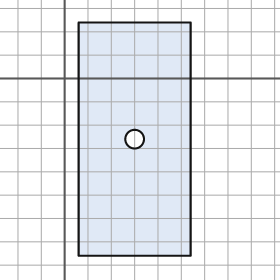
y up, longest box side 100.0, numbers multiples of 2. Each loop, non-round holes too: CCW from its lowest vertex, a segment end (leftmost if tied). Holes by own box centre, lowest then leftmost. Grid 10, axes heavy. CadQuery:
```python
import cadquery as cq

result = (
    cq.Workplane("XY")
    .moveTo(6.0, -76.0)
    .lineTo(54.0, -76.0)
    .lineTo(54.0, 24.0)
    .lineTo(6.0, 24.0)
    .close()
    .moveTo(30.0, -26.0)
    .circle(4.0)
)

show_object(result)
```